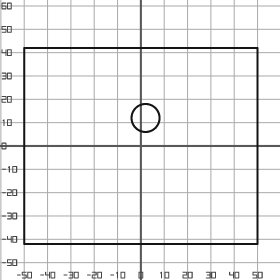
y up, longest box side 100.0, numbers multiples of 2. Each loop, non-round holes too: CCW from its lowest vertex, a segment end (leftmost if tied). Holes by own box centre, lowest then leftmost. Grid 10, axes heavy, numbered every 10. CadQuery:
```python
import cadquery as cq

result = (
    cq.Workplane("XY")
    .moveTo(-50.0, -42.0)
    .lineTo(50.0, -42.0)
    .lineTo(50.0, 42.0)
    .lineTo(-50.0, 42.0)
    .close()
    .moveTo(2.0, 12.0)
    .circle(6.0)
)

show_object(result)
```